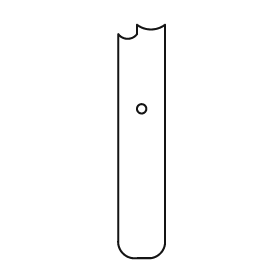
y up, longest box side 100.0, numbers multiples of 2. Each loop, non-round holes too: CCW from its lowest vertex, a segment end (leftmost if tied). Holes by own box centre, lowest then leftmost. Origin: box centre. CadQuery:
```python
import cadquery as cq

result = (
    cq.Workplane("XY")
    .moveTo(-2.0, -50.0)
    .lineTo(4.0, -50.0)
    .threePointArc((8.0, -48.0), (10.0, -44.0))
    .lineTo(10.0, 50.0)
    .threePointArc((4.0, 48.0), (-2.0, 50.0))
    .lineTo(-2.0, 46.0)
    .threePointArc((-6.0, 44.0), (-10.0, 46.0))
    .lineTo(-10.0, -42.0)
    .threePointArc((-8.0, -48.0), (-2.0, -50.0))
    .close()
    .moveTo(0.0, 14.0)
    .circle(2.0)
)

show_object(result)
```